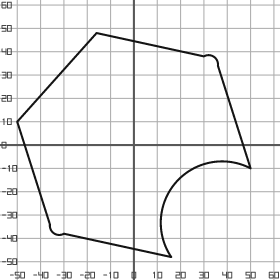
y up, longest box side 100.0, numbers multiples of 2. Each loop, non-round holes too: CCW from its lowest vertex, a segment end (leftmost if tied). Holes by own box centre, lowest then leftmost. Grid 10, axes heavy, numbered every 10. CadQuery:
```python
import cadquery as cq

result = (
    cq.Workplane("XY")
    .moveTo(16.0, -48.0)
    .threePointArc((18.0, -16.0), (50.0, -10.0))
    .lineTo(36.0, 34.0)
    .threePointArc((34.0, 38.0), (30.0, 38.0))
    .lineTo(-16.0, 48.0)
    .lineTo(-50.0, 10.0)
    .lineTo(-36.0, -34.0)
    .threePointArc((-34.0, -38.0), (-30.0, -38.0))
    .close()
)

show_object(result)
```